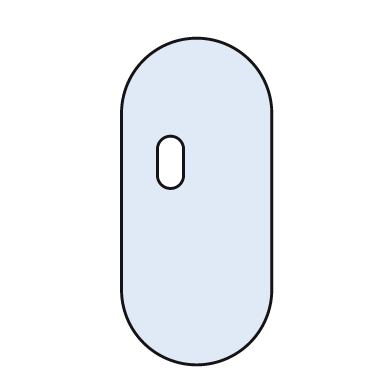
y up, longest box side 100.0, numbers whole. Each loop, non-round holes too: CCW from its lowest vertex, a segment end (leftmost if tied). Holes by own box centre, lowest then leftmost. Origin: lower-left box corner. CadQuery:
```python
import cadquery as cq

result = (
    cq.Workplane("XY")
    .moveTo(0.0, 23.0)
    .threePointArc((23.0, 0.0), (46.0, 23.0))
    .lineTo(46.0, 77.0)
    .threePointArc((23.0, 100.0), (0.0, 77.0))
    .close()
    .moveTo(11.0, 58.0)
    .threePointArc((15.0, 54.0), (19.0, 58.0))
    .lineTo(19.0, 66.0)
    .threePointArc((15.0, 70.0), (11.0, 66.0))
    .close()
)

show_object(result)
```